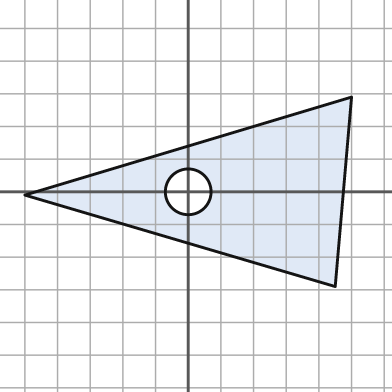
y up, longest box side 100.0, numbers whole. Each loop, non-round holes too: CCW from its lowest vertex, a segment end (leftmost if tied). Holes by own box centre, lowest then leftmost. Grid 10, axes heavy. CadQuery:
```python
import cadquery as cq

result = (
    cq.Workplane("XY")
    .moveTo(45.0, -29.0)
    .lineTo(50.0, 29.0)
    .lineTo(-50.0, -1.0)
    .close()
    .moveTo(0.0, 0.0)
    .circle(7.0)
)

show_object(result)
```